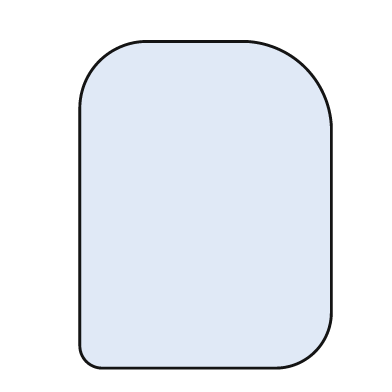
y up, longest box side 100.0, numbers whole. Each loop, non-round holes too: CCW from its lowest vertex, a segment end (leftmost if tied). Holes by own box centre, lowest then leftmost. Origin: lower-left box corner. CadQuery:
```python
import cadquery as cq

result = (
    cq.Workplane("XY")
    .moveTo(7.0, 0.0)
    .lineTo(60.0, 0.0)
    .threePointArc((72.0, 5.0), (77.0, 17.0))
    .lineTo(77.0, 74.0)
    .threePointArc((69.0, 92.0), (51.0, 100.0))
    .lineTo(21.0, 100.0)
    .threePointArc((6.0, 94.0), (0.0, 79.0))
    .lineTo(0.0, 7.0)
    .threePointArc((2.0, 2.0), (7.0, 0.0))
    .close()
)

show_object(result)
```